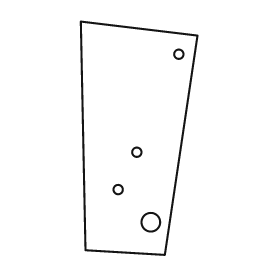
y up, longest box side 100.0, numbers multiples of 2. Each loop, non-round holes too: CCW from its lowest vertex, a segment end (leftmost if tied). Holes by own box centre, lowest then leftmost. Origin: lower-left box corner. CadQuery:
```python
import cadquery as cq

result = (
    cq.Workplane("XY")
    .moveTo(36.0, 0.0)
    .lineTo(50.0, 94.0)
    .lineTo(0.0, 100.0)
    .lineTo(2.0, 2.0)
    .close()
    .moveTo(30.0, 14.0)
    .circle(4.0)
    .moveTo(16.0, 28.0)
    .circle(2.0)
    .moveTo(24.0, 44.0)
    .circle(2.0)
    .moveTo(42.0, 86.0)
    .circle(2.0)
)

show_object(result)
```